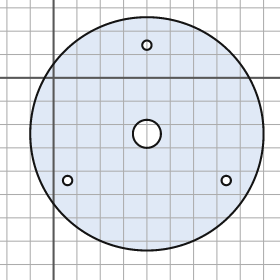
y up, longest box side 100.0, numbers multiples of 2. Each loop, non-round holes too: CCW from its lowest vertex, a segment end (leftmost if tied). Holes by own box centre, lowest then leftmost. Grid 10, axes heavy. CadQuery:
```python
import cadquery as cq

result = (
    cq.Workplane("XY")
    .moveTo(40.0, -24.0)
    .circle(50.0)
    .moveTo(6.0, -44.0)
    .circle(2.0)
    .moveTo(74.0, -44.0)
    .circle(2.0)
    .moveTo(40.0, -24.0)
    .circle(6.0)
    .moveTo(40.0, 14.0)
    .circle(2.0)
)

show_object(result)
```